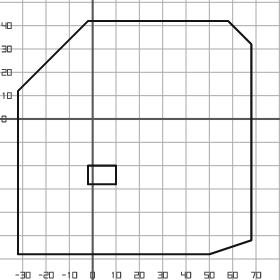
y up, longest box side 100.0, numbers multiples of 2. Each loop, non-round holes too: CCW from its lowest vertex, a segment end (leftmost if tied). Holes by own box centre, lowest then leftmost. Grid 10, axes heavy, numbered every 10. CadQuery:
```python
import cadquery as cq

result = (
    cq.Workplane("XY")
    .moveTo(-32.0, -58.0)
    .lineTo(50.0, -58.0)
    .lineTo(68.0, -52.0)
    .lineTo(68.0, 32.0)
    .lineTo(58.0, 42.0)
    .lineTo(-2.0, 42.0)
    .lineTo(-32.0, 12.0)
    .close()
    .moveTo(-2.0, -28.0)
    .lineTo(10.0, -28.0)
    .lineTo(10.0, -20.0)
    .lineTo(-2.0, -20.0)
    .close()
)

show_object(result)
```